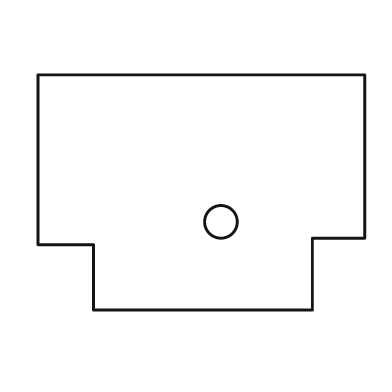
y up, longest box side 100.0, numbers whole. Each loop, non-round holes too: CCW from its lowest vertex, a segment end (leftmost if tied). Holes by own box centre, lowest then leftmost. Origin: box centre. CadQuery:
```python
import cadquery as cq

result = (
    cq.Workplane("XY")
    .moveTo(-33.0, -36.0)
    .lineTo(34.0, -36.0)
    .lineTo(34.0, -14.0)
    .lineTo(50.0, -14.0)
    .lineTo(50.0, 36.0)
    .lineTo(-50.0, 36.0)
    .lineTo(-50.0, -16.0)
    .lineTo(-33.0, -16.0)
    .close()
    .moveTo(6.0, -9.0)
    .circle(5.0)
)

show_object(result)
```